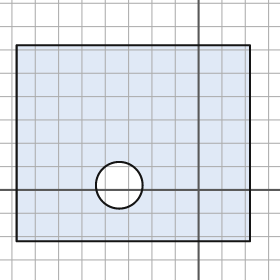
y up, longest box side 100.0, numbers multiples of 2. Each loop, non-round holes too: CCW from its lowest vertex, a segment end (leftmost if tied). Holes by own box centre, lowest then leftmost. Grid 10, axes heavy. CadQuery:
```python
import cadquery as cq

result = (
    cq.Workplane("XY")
    .moveTo(-78.0, -22.0)
    .lineTo(22.0, -22.0)
    .lineTo(22.0, 62.0)
    .lineTo(-78.0, 62.0)
    .close()
    .moveTo(-34.0, 2.0)
    .circle(10.0)
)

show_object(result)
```